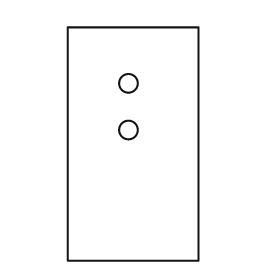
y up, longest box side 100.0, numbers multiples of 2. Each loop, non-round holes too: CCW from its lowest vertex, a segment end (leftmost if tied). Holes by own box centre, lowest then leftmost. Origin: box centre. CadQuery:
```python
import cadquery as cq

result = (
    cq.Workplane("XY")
    .moveTo(-28.0, -50.0)
    .lineTo(28.0, -50.0)
    .lineTo(28.0, 50.0)
    .lineTo(-28.0, 50.0)
    .close()
    .moveTo(-2.0, 6.0)
    .circle(4.0)
    .moveTo(-2.0, 26.0)
    .circle(4.0)
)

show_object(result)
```